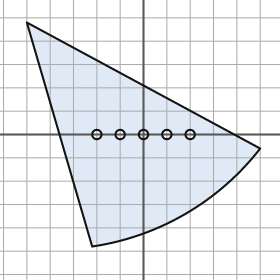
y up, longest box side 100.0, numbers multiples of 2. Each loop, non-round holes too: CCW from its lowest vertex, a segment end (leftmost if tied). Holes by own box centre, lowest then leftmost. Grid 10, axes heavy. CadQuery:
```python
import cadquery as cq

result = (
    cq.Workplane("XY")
    .moveTo(-22.0, -48.0)
    .threePointArc((18.0, -34.0), (50.0, -6.0))
    .lineTo(-50.0, 48.0)
    .close()
    .moveTo(-20.0, 0.0)
    .circle(2.0)
    .moveTo(-10.0, 0.0)
    .circle(2.0)
    .moveTo(0.0, 0.0)
    .circle(2.0)
    .moveTo(10.0, 0.0)
    .circle(2.0)
    .moveTo(20.0, 0.0)
    .circle(2.0)
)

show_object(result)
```